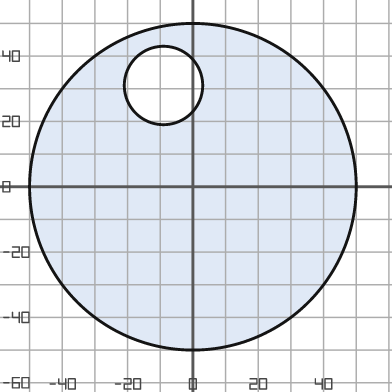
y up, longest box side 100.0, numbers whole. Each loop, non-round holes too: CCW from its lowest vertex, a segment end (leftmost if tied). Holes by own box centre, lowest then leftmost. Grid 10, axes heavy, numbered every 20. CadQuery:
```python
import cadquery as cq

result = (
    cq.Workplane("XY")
    .moveTo(0.0, 0.0)
    .circle(50.0)
    .moveTo(-9.0, 31.0)
    .circle(12.0)
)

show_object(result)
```